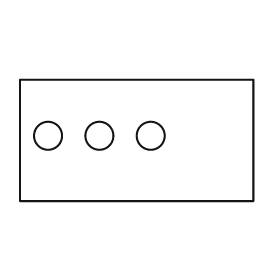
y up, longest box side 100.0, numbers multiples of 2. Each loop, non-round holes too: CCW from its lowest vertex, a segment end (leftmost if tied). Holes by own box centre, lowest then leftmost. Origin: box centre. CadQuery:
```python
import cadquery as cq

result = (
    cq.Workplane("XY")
    .moveTo(-50.0, -26.0)
    .lineTo(50.0, -26.0)
    .lineTo(50.0, 26.0)
    .lineTo(-50.0, 26.0)
    .close()
    .moveTo(-38.0, 2.0)
    .circle(6.0)
    .moveTo(-16.0, 2.0)
    .circle(6.0)
    .moveTo(6.0, 2.0)
    .circle(6.0)
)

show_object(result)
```